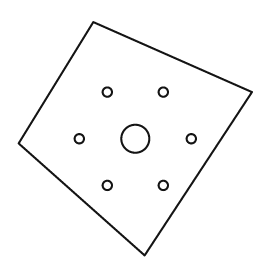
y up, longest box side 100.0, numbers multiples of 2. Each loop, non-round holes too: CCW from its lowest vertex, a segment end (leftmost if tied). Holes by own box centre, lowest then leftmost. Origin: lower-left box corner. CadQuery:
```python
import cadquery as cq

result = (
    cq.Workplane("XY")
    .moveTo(54.0, 0.0)
    .lineTo(100.0, 70.0)
    .lineTo(32.0, 100.0)
    .lineTo(0.0, 48.0)
    .close()
    .moveTo(38.0, 30.0)
    .circle(2.0)
    .moveTo(62.0, 30.0)
    .circle(2.0)
    .moveTo(26.0, 50.0)
    .circle(2.0)
    .moveTo(50.0, 50.0)
    .circle(6.0)
    .moveTo(74.0, 50.0)
    .circle(2.0)
    .moveTo(38.0, 70.0)
    .circle(2.0)
    .moveTo(62.0, 70.0)
    .circle(2.0)
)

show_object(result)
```